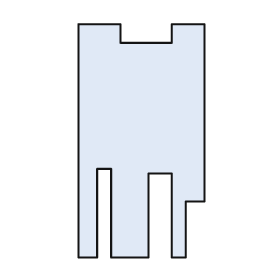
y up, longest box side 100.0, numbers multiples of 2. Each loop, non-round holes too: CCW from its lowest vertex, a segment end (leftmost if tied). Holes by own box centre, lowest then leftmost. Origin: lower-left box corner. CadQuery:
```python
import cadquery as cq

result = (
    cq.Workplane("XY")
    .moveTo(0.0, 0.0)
    .lineTo(8.0, 0.0)
    .lineTo(8.0, 38.0)
    .lineTo(14.0, 38.0)
    .lineTo(14.0, 0.0)
    .lineTo(30.0, 0.0)
    .lineTo(30.0, 36.0)
    .lineTo(40.0, 36.0)
    .lineTo(40.0, 0.0)
    .lineTo(46.0, 0.0)
    .lineTo(46.0, 24.0)
    .lineTo(54.0, 24.0)
    .lineTo(54.0, 100.0)
    .lineTo(40.0, 100.0)
    .lineTo(40.0, 92.0)
    .lineTo(18.0, 92.0)
    .lineTo(18.0, 100.0)
    .lineTo(0.0, 100.0)
    .close()
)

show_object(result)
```